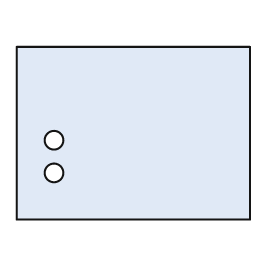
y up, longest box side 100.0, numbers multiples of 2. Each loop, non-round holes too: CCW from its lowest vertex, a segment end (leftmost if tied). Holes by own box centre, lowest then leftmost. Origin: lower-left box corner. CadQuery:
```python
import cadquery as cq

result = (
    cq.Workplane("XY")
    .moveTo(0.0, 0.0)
    .lineTo(100.0, 0.0)
    .lineTo(100.0, 74.0)
    .lineTo(0.0, 74.0)
    .close()
    .moveTo(16.0, 20.0)
    .circle(4.0)
    .moveTo(16.0, 34.0)
    .circle(4.0)
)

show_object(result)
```